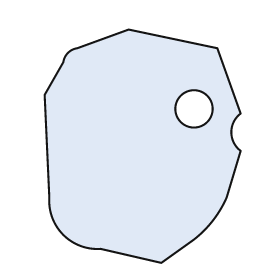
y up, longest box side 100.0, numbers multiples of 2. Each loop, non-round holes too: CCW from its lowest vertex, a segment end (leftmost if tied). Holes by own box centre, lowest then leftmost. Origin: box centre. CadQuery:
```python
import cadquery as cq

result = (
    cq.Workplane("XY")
    .moveTo(8.0, -50.0)
    .lineTo(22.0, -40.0)
    .threePointArc((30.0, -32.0), (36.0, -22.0))
    .lineTo(42.0, -2.0)
    .threePointArc((38.0, 6.0), (42.0, 14.0))
    .lineTo(32.0, 42.0)
    .lineTo(-6.0, 50.0)
    .lineTo(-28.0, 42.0)
    .threePointArc((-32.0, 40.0), (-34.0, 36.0))
    .lineTo(-42.0, 22.0)
    .lineTo(-40.0, -22.0)
    .threePointArc((-34.0, -38.0), (-18.0, -44.0))
    .close()
    .moveTo(22.0, 16.0)
    .circle(8.0)
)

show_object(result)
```